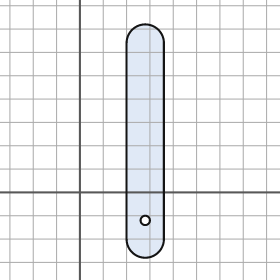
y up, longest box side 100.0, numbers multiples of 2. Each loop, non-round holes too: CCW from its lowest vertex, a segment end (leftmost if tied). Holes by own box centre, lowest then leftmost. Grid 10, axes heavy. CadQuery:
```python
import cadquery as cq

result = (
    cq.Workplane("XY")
    .moveTo(20.0, -20.0)
    .threePointArc((28.0, -28.0), (36.0, -20.0))
    .lineTo(36.0, 64.0)
    .threePointArc((28.0, 72.0), (20.0, 64.0))
    .close()
    .moveTo(28.0, -12.0)
    .circle(2.0)
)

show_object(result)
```